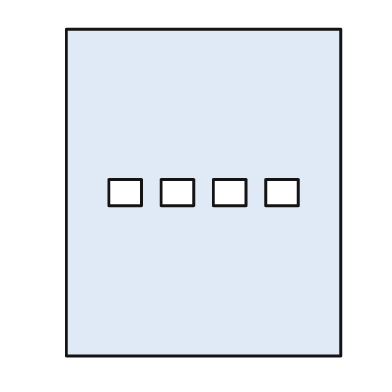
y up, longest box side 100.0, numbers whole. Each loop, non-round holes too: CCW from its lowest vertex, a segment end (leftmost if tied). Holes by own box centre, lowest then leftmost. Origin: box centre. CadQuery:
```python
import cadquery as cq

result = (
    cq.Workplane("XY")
    .moveTo(-42.0, -50.0)
    .lineTo(42.0, -50.0)
    .lineTo(42.0, 50.0)
    .lineTo(-42.0, 50.0)
    .close()
    .moveTo(-29.0, -4.0)
    .lineTo(-19.0, -4.0)
    .lineTo(-19.0, 4.0)
    .lineTo(-29.0, 4.0)
    .close()
    .moveTo(-13.0, -4.0)
    .lineTo(-3.0, -4.0)
    .lineTo(-3.0, 4.0)
    .lineTo(-13.0, 4.0)
    .close()
    .moveTo(3.0, -4.0)
    .lineTo(13.0, -4.0)
    .lineTo(13.0, 4.0)
    .lineTo(3.0, 4.0)
    .close()
    .moveTo(19.0, -4.0)
    .lineTo(29.0, -4.0)
    .lineTo(29.0, 4.0)
    .lineTo(19.0, 4.0)
    .close()
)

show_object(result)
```